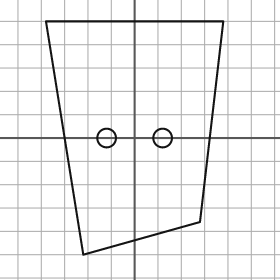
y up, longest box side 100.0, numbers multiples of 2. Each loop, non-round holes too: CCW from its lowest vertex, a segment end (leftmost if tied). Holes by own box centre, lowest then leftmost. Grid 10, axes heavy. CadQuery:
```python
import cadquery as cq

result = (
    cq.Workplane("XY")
    .moveTo(-22.0, -50.0)
    .lineTo(28.0, -36.0)
    .lineTo(38.0, 50.0)
    .lineTo(-38.0, 50.0)
    .close()
    .moveTo(-12.0, 0.0)
    .circle(4.0)
    .moveTo(12.0, 0.0)
    .circle(4.0)
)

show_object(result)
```